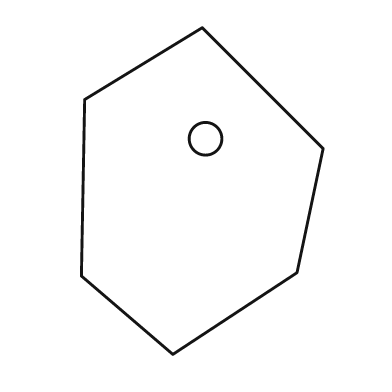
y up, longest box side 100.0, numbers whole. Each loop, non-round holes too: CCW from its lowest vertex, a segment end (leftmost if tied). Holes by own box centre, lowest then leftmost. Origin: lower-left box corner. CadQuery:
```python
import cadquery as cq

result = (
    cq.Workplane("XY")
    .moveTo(28.0, 0.0)
    .lineTo(66.0, 25.0)
    .lineTo(74.0, 63.0)
    .lineTo(37.0, 100.0)
    .lineTo(1.0, 78.0)
    .lineTo(0.0, 24.0)
    .close()
    .moveTo(38.0, 66.0)
    .circle(5.0)
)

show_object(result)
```